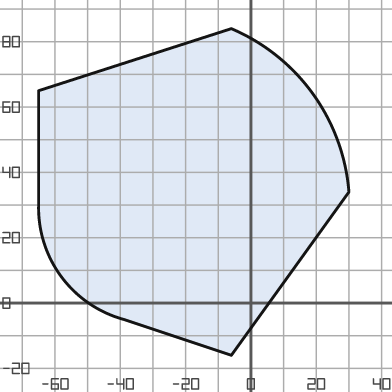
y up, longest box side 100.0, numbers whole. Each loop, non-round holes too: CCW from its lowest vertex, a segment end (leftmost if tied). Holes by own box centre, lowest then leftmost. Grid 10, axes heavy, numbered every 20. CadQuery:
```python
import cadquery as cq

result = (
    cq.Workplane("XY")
    .moveTo(-6.0, -16.0)
    .lineTo(30.0, 34.0)
    .threePointArc((19.0, 64.0), (-6.0, 84.0))
    .lineTo(-65.0, 65.0)
    .lineTo(-65.0, 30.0)
    .threePointArc((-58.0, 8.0), (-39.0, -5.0))
    .close()
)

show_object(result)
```